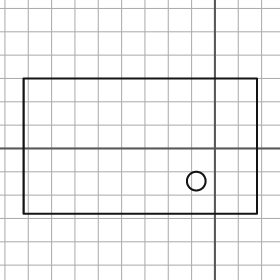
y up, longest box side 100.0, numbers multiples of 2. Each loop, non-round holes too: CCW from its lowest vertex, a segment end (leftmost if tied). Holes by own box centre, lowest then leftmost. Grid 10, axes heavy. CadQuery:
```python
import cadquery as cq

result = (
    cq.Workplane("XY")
    .moveTo(-82.0, -28.0)
    .lineTo(18.0, -28.0)
    .lineTo(18.0, 30.0)
    .lineTo(-82.0, 30.0)
    .close()
    .moveTo(-8.0, -14.0)
    .circle(4.0)
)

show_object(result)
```